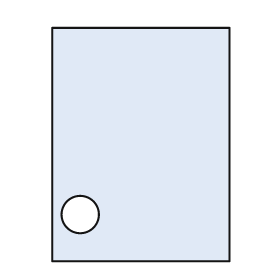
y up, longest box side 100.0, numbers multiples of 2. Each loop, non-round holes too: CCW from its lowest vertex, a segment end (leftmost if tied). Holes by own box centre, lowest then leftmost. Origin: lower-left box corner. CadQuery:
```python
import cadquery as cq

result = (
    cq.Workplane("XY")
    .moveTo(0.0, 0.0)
    .lineTo(76.0, 0.0)
    .lineTo(76.0, 100.0)
    .lineTo(0.0, 100.0)
    .close()
    .moveTo(12.0, 20.0)
    .circle(8.0)
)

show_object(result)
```